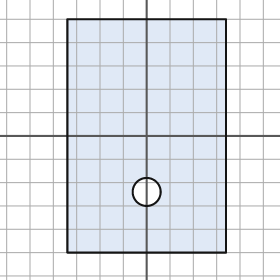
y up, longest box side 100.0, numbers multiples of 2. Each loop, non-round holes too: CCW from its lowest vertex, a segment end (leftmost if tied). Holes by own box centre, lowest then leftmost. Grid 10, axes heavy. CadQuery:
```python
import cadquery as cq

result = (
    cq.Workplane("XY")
    .moveTo(-34.0, -50.0)
    .lineTo(34.0, -50.0)
    .lineTo(34.0, 50.0)
    .lineTo(-34.0, 50.0)
    .close()
    .moveTo(0.0, -24.0)
    .circle(6.0)
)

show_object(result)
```